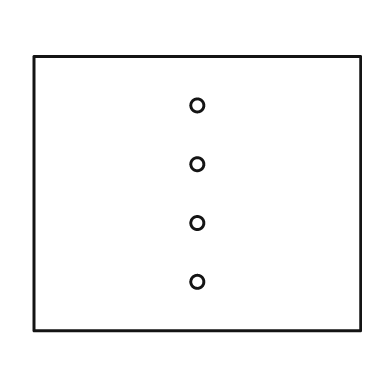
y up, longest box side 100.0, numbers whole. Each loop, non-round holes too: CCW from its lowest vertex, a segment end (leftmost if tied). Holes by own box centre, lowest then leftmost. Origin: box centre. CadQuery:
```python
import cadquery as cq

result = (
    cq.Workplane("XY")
    .moveTo(-50.0, -42.0)
    .lineTo(50.0, -42.0)
    .lineTo(50.0, 42.0)
    .lineTo(-50.0, 42.0)
    .close()
    .moveTo(0.0, -27.0)
    .circle(2.0)
    .moveTo(0.0, -9.0)
    .circle(2.0)
    .moveTo(0.0, 9.0)
    .circle(2.0)
    .moveTo(0.0, 27.0)
    .circle(2.0)
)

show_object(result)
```